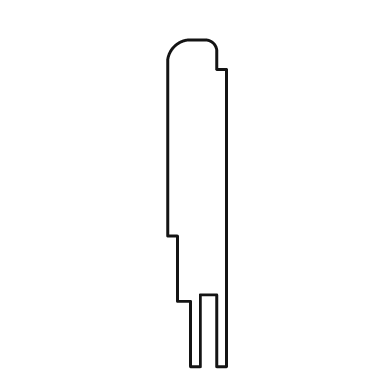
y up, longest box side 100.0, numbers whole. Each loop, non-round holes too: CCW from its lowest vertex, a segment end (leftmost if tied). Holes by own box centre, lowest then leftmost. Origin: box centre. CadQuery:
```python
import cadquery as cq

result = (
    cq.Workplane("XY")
    .moveTo(-2.0, -50.0)
    .lineTo(1.0, -50.0)
    .lineTo(1.0, -28.0)
    .lineTo(6.0, -28.0)
    .lineTo(6.0, -50.0)
    .lineTo(9.0, -50.0)
    .lineTo(9.0, 41.0)
    .lineTo(6.0, 41.0)
    .lineTo(6.0, 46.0)
    .threePointArc((5.0, 49.0), (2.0, 50.0))
    .lineTo(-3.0, 50.0)
    .threePointArc((-7.0, 48.0), (-9.0, 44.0))
    .lineTo(-9.0, -10.0)
    .lineTo(-6.0, -10.0)
    .lineTo(-6.0, -30.0)
    .lineTo(-2.0, -30.0)
    .close()
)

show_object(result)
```